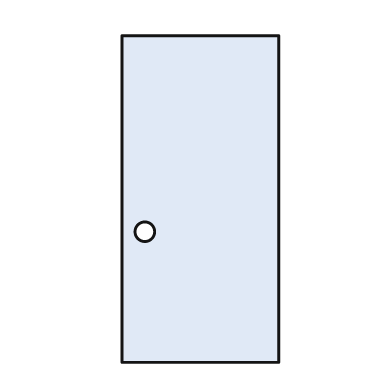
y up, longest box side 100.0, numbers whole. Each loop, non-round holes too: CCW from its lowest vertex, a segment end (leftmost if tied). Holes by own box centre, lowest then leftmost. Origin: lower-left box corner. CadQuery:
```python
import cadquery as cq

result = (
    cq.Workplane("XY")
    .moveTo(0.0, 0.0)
    .lineTo(48.0, 0.0)
    .lineTo(48.0, 100.0)
    .lineTo(0.0, 100.0)
    .close()
    .moveTo(7.0, 40.0)
    .circle(3.0)
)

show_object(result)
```